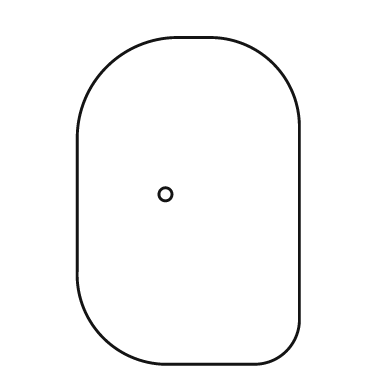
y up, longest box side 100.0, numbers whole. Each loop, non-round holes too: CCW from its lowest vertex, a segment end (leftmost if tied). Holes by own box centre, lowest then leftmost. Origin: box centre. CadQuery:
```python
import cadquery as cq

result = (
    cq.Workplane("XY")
    .moveTo(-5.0, -50.0)
    .lineTo(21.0, -50.0)
    .threePointArc((30.0, -46.0), (34.0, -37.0))
    .lineTo(34.0, 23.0)
    .threePointArc((26.0, 42.0), (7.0, 50.0))
    .lineTo(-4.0, 50.0)
    .threePointArc((-25.0, 41.0), (-34.0, 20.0))
    .lineTo(-34.0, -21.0)
    .threePointArc((-26.0, -42.0), (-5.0, -50.0))
    .close()
    .moveTo(-7.0, 2.0)
    .circle(2.0)
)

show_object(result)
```